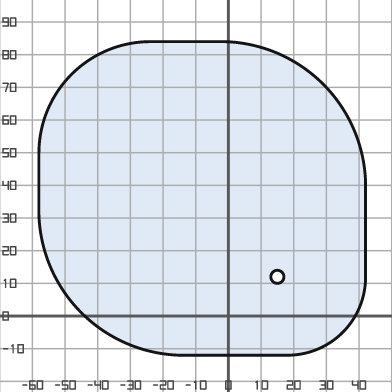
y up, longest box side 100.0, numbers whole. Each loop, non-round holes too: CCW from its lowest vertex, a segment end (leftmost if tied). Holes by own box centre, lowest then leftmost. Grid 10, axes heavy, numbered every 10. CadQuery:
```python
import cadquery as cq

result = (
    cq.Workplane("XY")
    .moveTo(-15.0, -12.0)
    .lineTo(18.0, -12.0)
    .threePointArc((35.0, -5.0), (42.0, 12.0))
    .lineTo(42.0, 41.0)
    .threePointArc((29.0, 71.0), (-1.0, 84.0))
    .lineTo(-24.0, 84.0)
    .threePointArc((-48.0, 74.0), (-58.0, 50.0))
    .lineTo(-58.0, 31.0)
    .threePointArc((-45.0, 1.0), (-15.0, -12.0))
    .close()
    .moveTo(15.0, 12.0)
    .circle(2.0)
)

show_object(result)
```